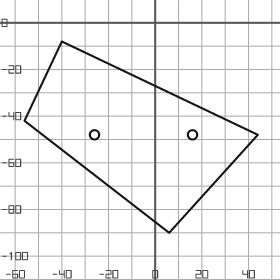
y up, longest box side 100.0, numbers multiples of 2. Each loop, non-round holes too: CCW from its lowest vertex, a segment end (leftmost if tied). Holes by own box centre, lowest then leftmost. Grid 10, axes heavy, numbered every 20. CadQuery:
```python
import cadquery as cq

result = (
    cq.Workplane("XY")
    .moveTo(6.0, -90.0)
    .lineTo(44.0, -48.0)
    .lineTo(-40.0, -8.0)
    .lineTo(-56.0, -42.0)
    .close()
    .moveTo(-26.0, -48.0)
    .circle(2.0)
    .moveTo(16.0, -48.0)
    .circle(2.0)
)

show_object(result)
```